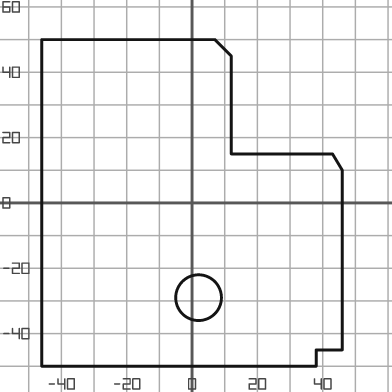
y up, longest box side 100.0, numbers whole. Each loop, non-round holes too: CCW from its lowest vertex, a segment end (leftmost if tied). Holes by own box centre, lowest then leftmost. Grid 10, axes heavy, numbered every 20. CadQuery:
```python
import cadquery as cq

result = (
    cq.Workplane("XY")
    .moveTo(-46.0, -50.0)
    .lineTo(38.0, -50.0)
    .lineTo(38.0, -45.0)
    .lineTo(46.0, -45.0)
    .lineTo(46.0, 10.0)
    .lineTo(43.0, 15.0)
    .lineTo(12.0, 15.0)
    .lineTo(12.0, 45.0)
    .lineTo(7.0, 50.0)
    .lineTo(-46.0, 50.0)
    .close()
    .moveTo(2.0, -29.0)
    .circle(7.0)
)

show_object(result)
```